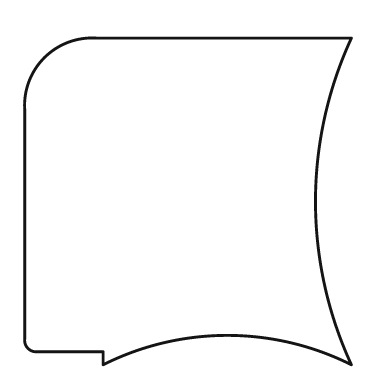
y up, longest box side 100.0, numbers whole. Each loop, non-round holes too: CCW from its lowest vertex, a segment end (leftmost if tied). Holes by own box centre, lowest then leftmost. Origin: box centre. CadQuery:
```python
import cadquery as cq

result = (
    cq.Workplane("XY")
    .moveTo(-26.0, -50.0)
    .threePointArc((12.0, -41.0), (50.0, -50.0))
    .threePointArc((39.0, 0.0), (50.0, 50.0))
    .lineTo(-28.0, 50.0)
    .threePointArc((-44.0, 44.0), (-50.0, 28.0))
    .lineTo(-50.0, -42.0)
    .threePointArc((-49.0, -45.0), (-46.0, -46.0))
    .lineTo(-26.0, -46.0)
    .close()
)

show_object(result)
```